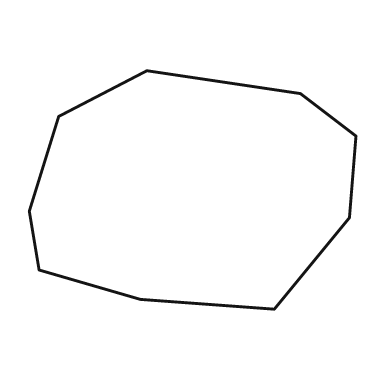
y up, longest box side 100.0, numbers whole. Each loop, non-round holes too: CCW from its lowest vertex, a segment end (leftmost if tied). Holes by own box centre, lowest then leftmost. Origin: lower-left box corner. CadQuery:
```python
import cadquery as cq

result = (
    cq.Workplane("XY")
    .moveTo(75.0, 0.0)
    .lineTo(98.0, 28.0)
    .lineTo(100.0, 53.0)
    .lineTo(83.0, 66.0)
    .lineTo(36.0, 73.0)
    .lineTo(9.0, 59.0)
    .lineTo(0.0, 30.0)
    .lineTo(3.0, 12.0)
    .lineTo(34.0, 3.0)
    .close()
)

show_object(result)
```